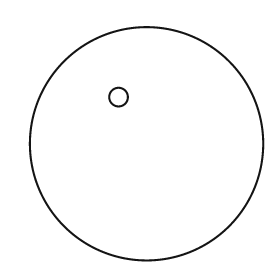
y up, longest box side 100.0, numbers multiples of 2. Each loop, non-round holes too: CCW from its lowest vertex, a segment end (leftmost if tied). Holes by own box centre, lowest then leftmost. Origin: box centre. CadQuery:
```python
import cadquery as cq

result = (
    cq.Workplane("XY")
    .moveTo(0.0, 0.0)
    .circle(50.0)
    .moveTo(-12.0, 20.0)
    .circle(4.0)
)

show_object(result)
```